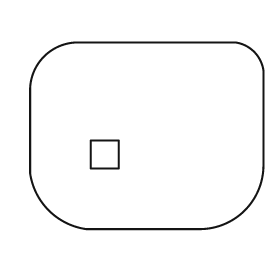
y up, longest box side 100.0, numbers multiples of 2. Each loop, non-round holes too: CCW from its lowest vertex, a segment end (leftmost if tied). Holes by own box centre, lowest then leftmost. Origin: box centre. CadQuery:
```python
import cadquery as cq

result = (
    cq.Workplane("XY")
    .moveTo(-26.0, -40.0)
    .lineTo(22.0, -40.0)
    .threePointArc((42.0, -32.0), (50.0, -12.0))
    .lineTo(50.0, 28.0)
    .threePointArc((46.0, 36.0), (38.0, 40.0))
    .lineTo(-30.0, 40.0)
    .threePointArc((-44.0, 34.0), (-50.0, 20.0))
    .lineTo(-50.0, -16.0)
    .threePointArc((-42.0, -32.0), (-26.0, -40.0))
    .close()
    .moveTo(-24.0, -14.0)
    .lineTo(-12.0, -14.0)
    .lineTo(-12.0, -2.0)
    .lineTo(-24.0, -2.0)
    .close()
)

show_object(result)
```